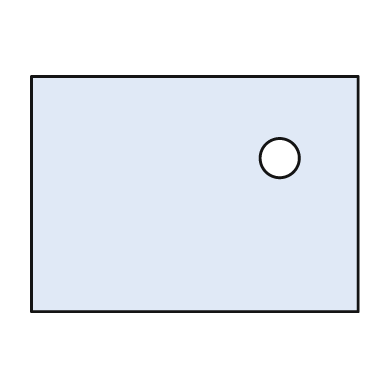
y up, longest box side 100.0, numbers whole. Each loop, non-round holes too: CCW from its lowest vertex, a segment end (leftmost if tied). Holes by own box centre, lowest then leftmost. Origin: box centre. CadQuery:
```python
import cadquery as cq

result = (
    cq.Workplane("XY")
    .moveTo(-50.0, -36.0)
    .lineTo(50.0, -36.0)
    .lineTo(50.0, 36.0)
    .lineTo(-50.0, 36.0)
    .close()
    .moveTo(26.0, 11.0)
    .circle(6.0)
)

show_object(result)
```